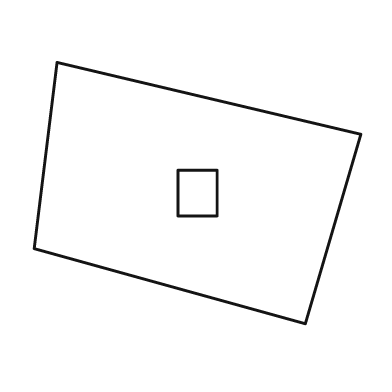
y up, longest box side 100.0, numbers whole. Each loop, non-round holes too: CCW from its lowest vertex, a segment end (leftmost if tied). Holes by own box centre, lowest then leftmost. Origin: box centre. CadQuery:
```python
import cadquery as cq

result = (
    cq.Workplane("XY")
    .moveTo(33.0, -40.0)
    .lineTo(50.0, 18.0)
    .lineTo(-43.0, 40.0)
    .lineTo(-50.0, -17.0)
    .close()
    .moveTo(-6.0, -7.0)
    .lineTo(6.0, -7.0)
    .lineTo(6.0, 7.0)
    .lineTo(-6.0, 7.0)
    .close()
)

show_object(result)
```